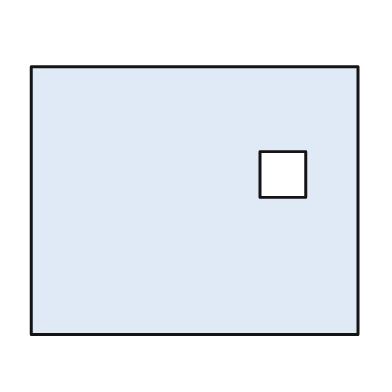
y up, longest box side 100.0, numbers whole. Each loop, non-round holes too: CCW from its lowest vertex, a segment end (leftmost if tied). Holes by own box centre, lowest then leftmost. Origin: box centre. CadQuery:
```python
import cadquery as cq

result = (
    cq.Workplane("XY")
    .moveTo(-50.0, -41.0)
    .lineTo(50.0, -41.0)
    .lineTo(50.0, 41.0)
    .lineTo(-50.0, 41.0)
    .close()
    .moveTo(20.0, 1.0)
    .lineTo(34.0, 1.0)
    .lineTo(34.0, 15.0)
    .lineTo(20.0, 15.0)
    .close()
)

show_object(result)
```